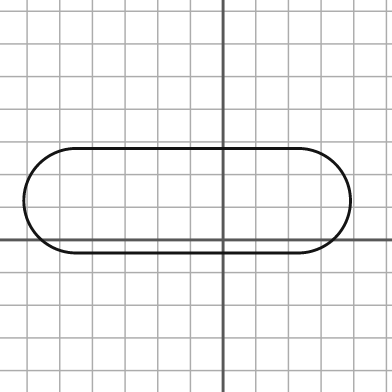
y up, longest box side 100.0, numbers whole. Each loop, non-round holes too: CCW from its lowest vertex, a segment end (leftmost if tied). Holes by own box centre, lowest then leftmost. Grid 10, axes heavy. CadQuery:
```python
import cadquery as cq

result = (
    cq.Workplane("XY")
    .moveTo(-45.0, -4.0)
    .lineTo(23.0, -4.0)
    .threePointArc((39.0, 12.0), (23.0, 28.0))
    .lineTo(-45.0, 28.0)
    .threePointArc((-61.0, 12.0), (-45.0, -4.0))
    .close()
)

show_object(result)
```